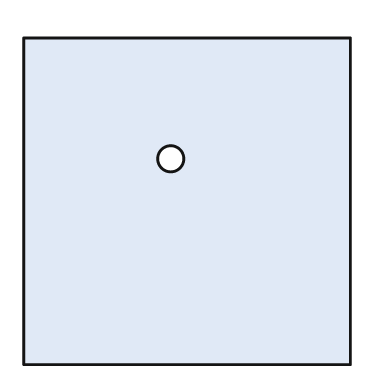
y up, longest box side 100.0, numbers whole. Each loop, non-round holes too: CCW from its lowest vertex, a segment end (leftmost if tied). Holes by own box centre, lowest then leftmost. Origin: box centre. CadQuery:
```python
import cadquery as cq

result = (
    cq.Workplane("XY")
    .moveTo(-50.0, -50.0)
    .lineTo(50.0, -50.0)
    .lineTo(50.0, 50.0)
    .lineTo(-50.0, 50.0)
    .close()
    .moveTo(-5.0, 13.0)
    .circle(4.0)
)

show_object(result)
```